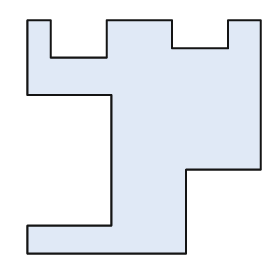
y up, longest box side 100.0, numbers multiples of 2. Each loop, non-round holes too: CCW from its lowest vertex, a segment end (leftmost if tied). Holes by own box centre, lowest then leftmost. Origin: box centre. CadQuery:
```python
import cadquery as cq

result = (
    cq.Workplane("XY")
    .moveTo(-50.0, -50.0)
    .lineTo(18.0, -50.0)
    .lineTo(18.0, -14.0)
    .lineTo(50.0, -14.0)
    .lineTo(50.0, 50.0)
    .lineTo(36.0, 50.0)
    .lineTo(36.0, 38.0)
    .lineTo(12.0, 38.0)
    .lineTo(12.0, 50.0)
    .lineTo(-16.0, 50.0)
    .lineTo(-16.0, 34.0)
    .lineTo(-40.0, 34.0)
    .lineTo(-40.0, 50.0)
    .lineTo(-50.0, 50.0)
    .lineTo(-50.0, 18.0)
    .lineTo(-14.0, 18.0)
    .lineTo(-14.0, -38.0)
    .lineTo(-50.0, -38.0)
    .close()
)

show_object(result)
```